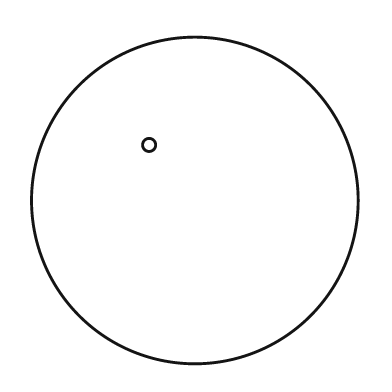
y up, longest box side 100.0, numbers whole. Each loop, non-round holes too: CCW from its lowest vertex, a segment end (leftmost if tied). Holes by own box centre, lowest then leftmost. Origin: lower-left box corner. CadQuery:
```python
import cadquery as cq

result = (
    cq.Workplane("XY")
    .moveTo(50.0, 50.0)
    .circle(50.0)
    .moveTo(36.0, 67.0)
    .circle(2.0)
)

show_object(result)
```